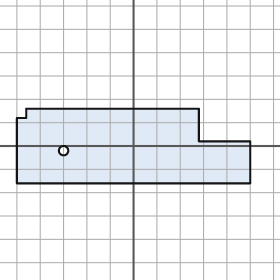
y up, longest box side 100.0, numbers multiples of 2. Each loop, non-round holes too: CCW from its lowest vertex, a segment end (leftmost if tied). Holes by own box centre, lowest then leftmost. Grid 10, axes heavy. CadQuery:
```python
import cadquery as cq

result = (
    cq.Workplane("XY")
    .moveTo(-50.0, -16.0)
    .lineTo(50.0, -16.0)
    .lineTo(50.0, 2.0)
    .lineTo(28.0, 2.0)
    .lineTo(28.0, 16.0)
    .lineTo(-46.0, 16.0)
    .lineTo(-46.0, 12.0)
    .lineTo(-50.0, 12.0)
    .close()
    .moveTo(-30.0, -2.0)
    .circle(2.0)
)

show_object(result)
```